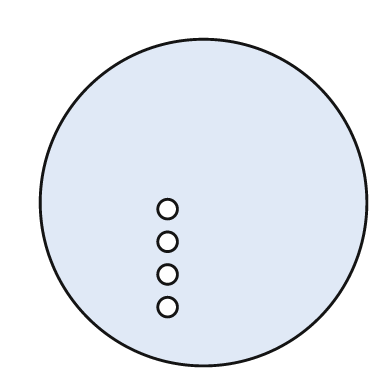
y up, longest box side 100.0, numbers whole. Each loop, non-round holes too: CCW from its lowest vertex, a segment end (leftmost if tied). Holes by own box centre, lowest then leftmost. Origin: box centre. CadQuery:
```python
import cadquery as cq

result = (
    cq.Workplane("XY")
    .moveTo(0.0, 0.0)
    .circle(50.0)
    .moveTo(-11.0, -32.0)
    .circle(3.0)
    .moveTo(-11.0, -22.0)
    .circle(3.0)
    .moveTo(-11.0, -12.0)
    .circle(3.0)
    .moveTo(-11.0, -2.0)
    .circle(3.0)
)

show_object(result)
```